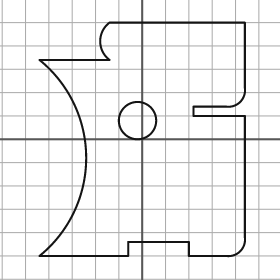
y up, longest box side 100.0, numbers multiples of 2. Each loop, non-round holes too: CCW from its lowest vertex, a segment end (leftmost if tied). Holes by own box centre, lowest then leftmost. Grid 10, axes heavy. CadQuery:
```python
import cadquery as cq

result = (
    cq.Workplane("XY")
    .moveTo(-44.0, -50.0)
    .lineTo(-6.0, -50.0)
    .lineTo(-6.0, -44.0)
    .lineTo(20.0, -44.0)
    .lineTo(20.0, -50.0)
    .lineTo(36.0, -50.0)
    .threePointArc((42.0, -48.0), (44.0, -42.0))
    .lineTo(44.0, 10.0)
    .lineTo(22.0, 10.0)
    .lineTo(22.0, 14.0)
    .lineTo(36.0, 14.0)
    .threePointArc((42.0, 16.0), (44.0, 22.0))
    .lineTo(44.0, 50.0)
    .lineTo(-14.0, 50.0)
    .threePointArc((-18.0, 42.0), (-14.0, 34.0))
    .lineTo(-44.0, 34.0)
    .threePointArc((-24.0, -8.0), (-44.0, -50.0))
    .close()
    .moveTo(-2.0, 8.0)
    .circle(8.0)
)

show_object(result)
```